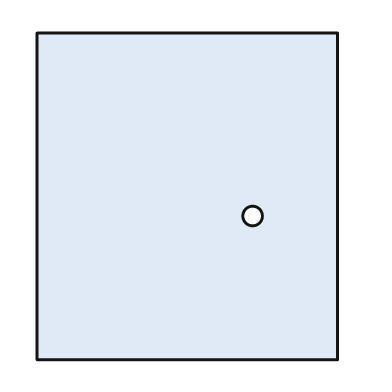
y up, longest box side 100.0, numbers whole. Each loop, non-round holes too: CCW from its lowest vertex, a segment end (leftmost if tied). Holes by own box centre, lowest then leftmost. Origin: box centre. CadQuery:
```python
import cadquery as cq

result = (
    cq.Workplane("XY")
    .moveTo(-46.0, -50.0)
    .lineTo(46.0, -50.0)
    .lineTo(46.0, 50.0)
    .lineTo(-46.0, 50.0)
    .close()
    .moveTo(20.0, -6.0)
    .circle(3.0)
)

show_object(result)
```